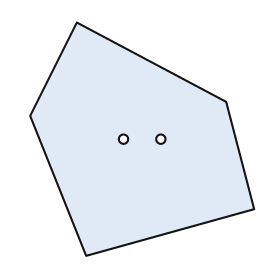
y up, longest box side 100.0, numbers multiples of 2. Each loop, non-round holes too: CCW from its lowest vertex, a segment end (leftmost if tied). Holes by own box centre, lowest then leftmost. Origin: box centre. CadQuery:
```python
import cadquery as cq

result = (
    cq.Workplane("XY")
    .moveTo(-24.0, -50.0)
    .lineTo(48.0, -30.0)
    .lineTo(36.0, 16.0)
    .lineTo(-28.0, 50.0)
    .lineTo(-48.0, 10.0)
    .close()
    .moveTo(-8.0, 0.0)
    .circle(2.0)
    .moveTo(8.0, 0.0)
    .circle(2.0)
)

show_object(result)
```